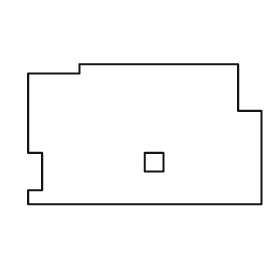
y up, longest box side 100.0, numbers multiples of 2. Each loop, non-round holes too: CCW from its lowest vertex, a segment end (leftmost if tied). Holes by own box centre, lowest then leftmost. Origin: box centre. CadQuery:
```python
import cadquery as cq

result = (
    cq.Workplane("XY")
    .moveTo(-50.0, -30.0)
    .lineTo(50.0, -30.0)
    .lineTo(50.0, 10.0)
    .lineTo(40.0, 10.0)
    .lineTo(40.0, 30.0)
    .lineTo(-28.0, 30.0)
    .lineTo(-28.0, 26.0)
    .lineTo(-50.0, 26.0)
    .lineTo(-50.0, -8.0)
    .lineTo(-44.0, -8.0)
    .lineTo(-44.0, -24.0)
    .lineTo(-50.0, -24.0)
    .close()
    .moveTo(0.0, -16.0)
    .lineTo(8.0, -16.0)
    .lineTo(8.0, -8.0)
    .lineTo(0.0, -8.0)
    .close()
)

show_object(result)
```